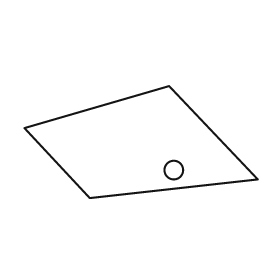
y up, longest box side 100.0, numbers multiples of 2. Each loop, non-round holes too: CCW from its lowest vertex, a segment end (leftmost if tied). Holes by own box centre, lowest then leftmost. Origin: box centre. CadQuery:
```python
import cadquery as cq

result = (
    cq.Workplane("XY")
    .moveTo(-22.0, -24.0)
    .lineTo(50.0, -16.0)
    .lineTo(12.0, 24.0)
    .lineTo(-50.0, 6.0)
    .close()
    .moveTo(14.0, -12.0)
    .circle(4.0)
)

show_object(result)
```